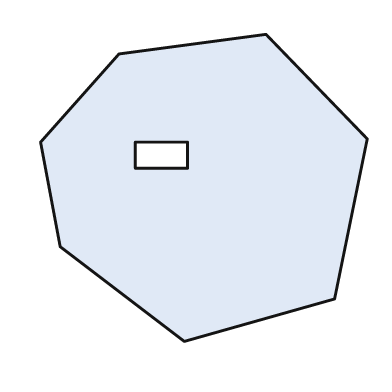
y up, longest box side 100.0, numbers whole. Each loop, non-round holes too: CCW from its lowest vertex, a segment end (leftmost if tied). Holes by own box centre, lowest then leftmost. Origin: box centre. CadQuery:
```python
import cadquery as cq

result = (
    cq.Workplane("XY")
    .moveTo(-6.0, -47.0)
    .lineTo(40.0, -34.0)
    .lineTo(50.0, 15.0)
    .lineTo(19.0, 47.0)
    .lineTo(-26.0, 41.0)
    .lineTo(-50.0, 14.0)
    .lineTo(-44.0, -18.0)
    .close()
    .moveTo(-21.0, 6.0)
    .lineTo(-5.0, 6.0)
    .lineTo(-5.0, 14.0)
    .lineTo(-21.0, 14.0)
    .close()
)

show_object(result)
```